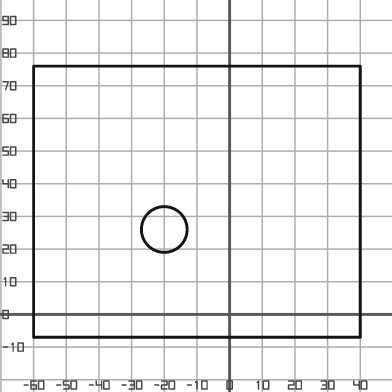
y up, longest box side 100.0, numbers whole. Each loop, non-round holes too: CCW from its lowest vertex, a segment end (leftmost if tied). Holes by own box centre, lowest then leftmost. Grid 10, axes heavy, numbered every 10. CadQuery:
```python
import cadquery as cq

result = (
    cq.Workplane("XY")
    .moveTo(-60.0, -7.0)
    .lineTo(40.0, -7.0)
    .lineTo(40.0, 76.0)
    .lineTo(-60.0, 76.0)
    .close()
    .moveTo(-20.0, 26.0)
    .circle(7.0)
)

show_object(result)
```